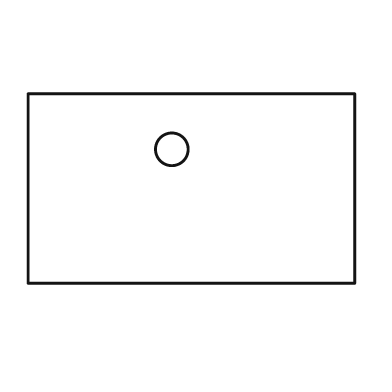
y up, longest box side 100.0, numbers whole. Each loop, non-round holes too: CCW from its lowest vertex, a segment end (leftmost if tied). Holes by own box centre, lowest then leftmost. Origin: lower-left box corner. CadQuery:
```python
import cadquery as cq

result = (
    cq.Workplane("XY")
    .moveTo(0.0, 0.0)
    .lineTo(100.0, 0.0)
    .lineTo(100.0, 58.0)
    .lineTo(0.0, 58.0)
    .close()
    .moveTo(44.0, 41.0)
    .circle(5.0)
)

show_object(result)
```